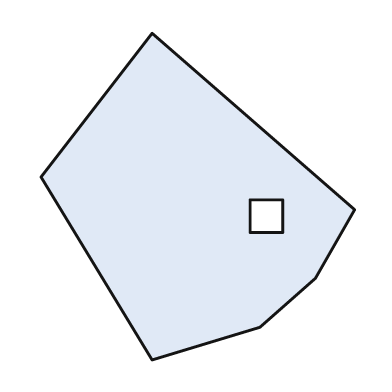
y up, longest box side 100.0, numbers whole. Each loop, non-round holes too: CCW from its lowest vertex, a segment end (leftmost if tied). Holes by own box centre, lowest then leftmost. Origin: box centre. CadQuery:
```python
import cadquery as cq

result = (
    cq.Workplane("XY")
    .moveTo(-14.0, -50.0)
    .lineTo(19.0, -40.0)
    .lineTo(36.0, -25.0)
    .lineTo(48.0, -4.0)
    .lineTo(-14.0, 50.0)
    .lineTo(-48.0, 6.0)
    .close()
    .moveTo(16.0, -11.0)
    .lineTo(26.0, -11.0)
    .lineTo(26.0, -1.0)
    .lineTo(16.0, -1.0)
    .close()
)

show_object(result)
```